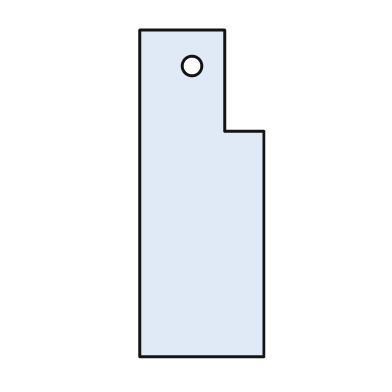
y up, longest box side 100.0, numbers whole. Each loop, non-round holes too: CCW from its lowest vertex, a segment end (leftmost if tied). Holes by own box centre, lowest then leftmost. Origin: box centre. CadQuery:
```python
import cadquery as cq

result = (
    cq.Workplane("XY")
    .moveTo(-19.0, -50.0)
    .lineTo(19.0, -50.0)
    .lineTo(19.0, 19.0)
    .lineTo(7.0, 19.0)
    .lineTo(7.0, 50.0)
    .lineTo(-19.0, 50.0)
    .close()
    .moveTo(-3.0, 39.0)
    .circle(3.0)
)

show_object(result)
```